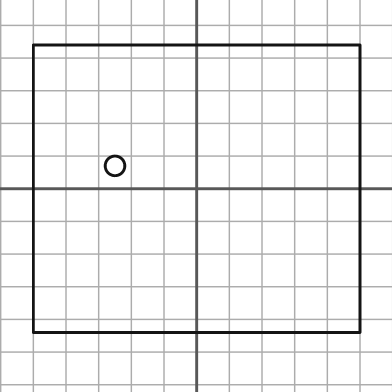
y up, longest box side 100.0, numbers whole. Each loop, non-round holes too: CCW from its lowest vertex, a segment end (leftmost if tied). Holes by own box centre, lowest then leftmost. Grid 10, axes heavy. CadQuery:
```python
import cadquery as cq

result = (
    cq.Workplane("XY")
    .moveTo(-50.0, -44.0)
    .lineTo(50.0, -44.0)
    .lineTo(50.0, 44.0)
    .lineTo(-50.0, 44.0)
    .close()
    .moveTo(-25.0, 7.0)
    .circle(3.0)
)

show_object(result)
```